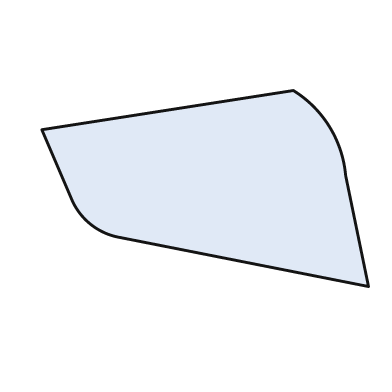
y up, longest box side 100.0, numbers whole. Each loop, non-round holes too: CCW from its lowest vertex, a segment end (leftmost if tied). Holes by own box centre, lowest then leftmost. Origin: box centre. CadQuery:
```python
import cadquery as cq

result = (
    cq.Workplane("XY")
    .moveTo(50.0, -30.0)
    .lineTo(43.0, 4.0)
    .threePointArc((38.0, 19.0), (27.0, 30.0))
    .lineTo(-50.0, 18.0)
    .lineTo(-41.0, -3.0)
    .threePointArc((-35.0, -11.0), (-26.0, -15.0))
    .close()
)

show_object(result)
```